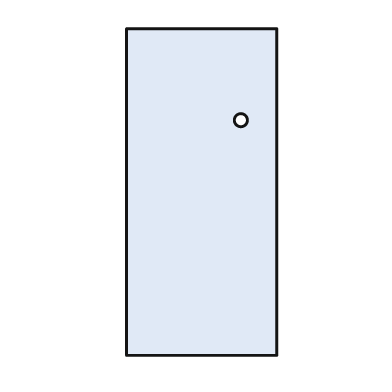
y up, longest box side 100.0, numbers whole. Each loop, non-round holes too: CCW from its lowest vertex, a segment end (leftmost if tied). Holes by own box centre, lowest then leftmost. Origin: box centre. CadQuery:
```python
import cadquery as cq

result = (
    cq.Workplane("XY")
    .moveTo(-23.0, -50.0)
    .lineTo(23.0, -50.0)
    .lineTo(23.0, 50.0)
    .lineTo(-23.0, 50.0)
    .close()
    .moveTo(12.0, 22.0)
    .circle(2.0)
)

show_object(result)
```